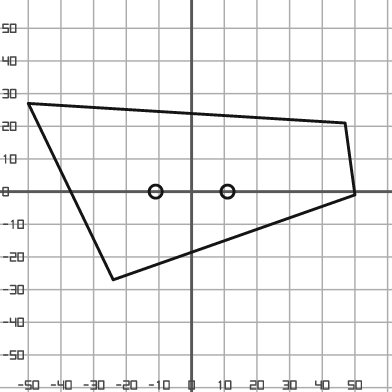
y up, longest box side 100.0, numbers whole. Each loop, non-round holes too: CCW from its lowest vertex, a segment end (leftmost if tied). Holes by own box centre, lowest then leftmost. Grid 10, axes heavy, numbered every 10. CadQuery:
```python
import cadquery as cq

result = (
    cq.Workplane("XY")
    .moveTo(-24.0, -27.0)
    .lineTo(50.0, -1.0)
    .lineTo(47.0, 21.0)
    .lineTo(-50.0, 27.0)
    .close()
    .moveTo(-11.0, 0.0)
    .circle(2.0)
    .moveTo(11.0, 0.0)
    .circle(2.0)
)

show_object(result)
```